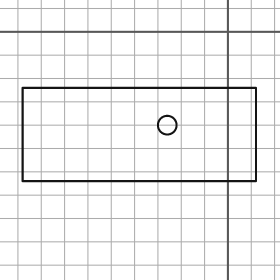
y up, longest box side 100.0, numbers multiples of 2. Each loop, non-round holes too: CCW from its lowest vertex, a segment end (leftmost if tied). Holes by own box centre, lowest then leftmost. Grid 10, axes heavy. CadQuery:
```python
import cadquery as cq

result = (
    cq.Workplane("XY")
    .moveTo(-88.0, -64.0)
    .lineTo(12.0, -64.0)
    .lineTo(12.0, -24.0)
    .lineTo(-88.0, -24.0)
    .close()
    .moveTo(-26.0, -40.0)
    .circle(4.0)
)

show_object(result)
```